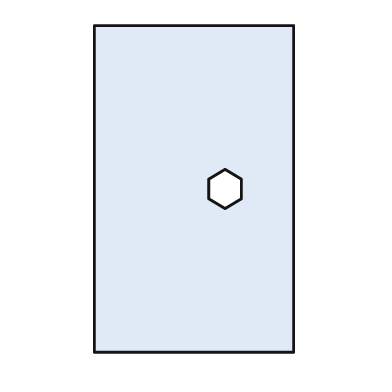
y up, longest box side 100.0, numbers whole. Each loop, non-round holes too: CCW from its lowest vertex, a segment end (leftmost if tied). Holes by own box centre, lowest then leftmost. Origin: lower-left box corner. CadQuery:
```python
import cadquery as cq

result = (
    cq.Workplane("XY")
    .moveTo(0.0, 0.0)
    .lineTo(61.0, 0.0)
    .lineTo(61.0, 100.0)
    .lineTo(0.0, 100.0)
    .close()
    .moveTo(40.0, 44.0)
    .lineTo(45.0, 47.0)
    .lineTo(45.0, 53.0)
    .lineTo(40.0, 56.0)
    .lineTo(35.0, 53.0)
    .lineTo(35.0, 47.0)
    .close()
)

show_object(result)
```